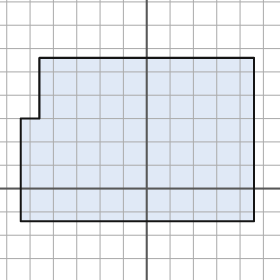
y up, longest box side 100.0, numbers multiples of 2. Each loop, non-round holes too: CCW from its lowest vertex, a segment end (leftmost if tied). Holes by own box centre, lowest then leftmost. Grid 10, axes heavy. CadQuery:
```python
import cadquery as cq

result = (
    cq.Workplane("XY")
    .moveTo(-54.0, -14.0)
    .lineTo(46.0, -14.0)
    .lineTo(46.0, 56.0)
    .lineTo(-46.0, 56.0)
    .lineTo(-46.0, 30.0)
    .lineTo(-54.0, 30.0)
    .close()
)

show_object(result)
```